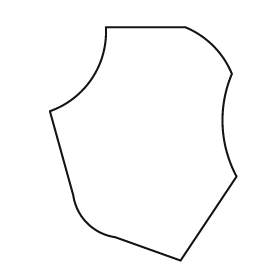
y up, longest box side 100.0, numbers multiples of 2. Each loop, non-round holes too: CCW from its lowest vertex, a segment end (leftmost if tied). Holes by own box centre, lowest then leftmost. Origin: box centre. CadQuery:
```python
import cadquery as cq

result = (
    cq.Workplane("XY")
    .moveTo(16.0, -50.0)
    .lineTo(40.0, -14.0)
    .threePointArc((34.0, 8.0), (38.0, 30.0))
    .threePointArc((30.0, 42.0), (18.0, 50.0))
    .lineTo(-16.0, 50.0)
    .threePointArc((-22.0, 28.0), (-40.0, 14.0))
    .lineTo(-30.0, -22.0)
    .threePointArc((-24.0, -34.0), (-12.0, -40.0))
    .close()
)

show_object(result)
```